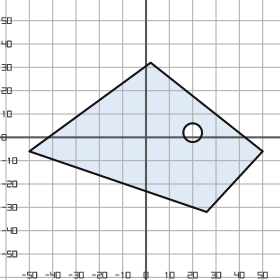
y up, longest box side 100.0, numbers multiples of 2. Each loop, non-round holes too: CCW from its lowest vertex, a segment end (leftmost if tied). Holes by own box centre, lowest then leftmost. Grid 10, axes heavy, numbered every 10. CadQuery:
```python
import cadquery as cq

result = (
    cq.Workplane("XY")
    .moveTo(26.0, -32.0)
    .lineTo(50.0, -6.0)
    .lineTo(2.0, 32.0)
    .lineTo(-50.0, -6.0)
    .close()
    .moveTo(20.0, 2.0)
    .circle(4.0)
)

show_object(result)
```